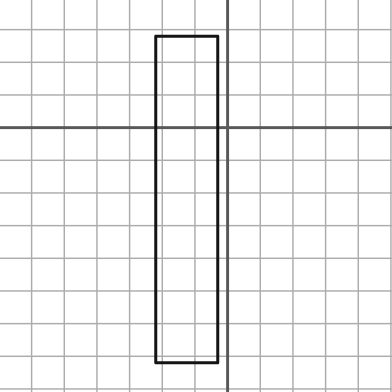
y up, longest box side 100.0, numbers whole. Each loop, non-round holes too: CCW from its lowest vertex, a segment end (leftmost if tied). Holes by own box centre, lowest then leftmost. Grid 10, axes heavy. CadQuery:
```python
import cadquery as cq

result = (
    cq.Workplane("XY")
    .moveTo(-22.0, -72.0)
    .lineTo(-3.0, -72.0)
    .lineTo(-3.0, 28.0)
    .lineTo(-22.0, 28.0)
    .close()
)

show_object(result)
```